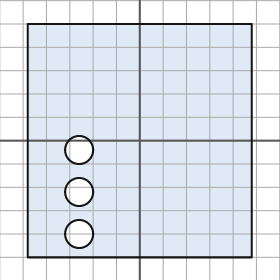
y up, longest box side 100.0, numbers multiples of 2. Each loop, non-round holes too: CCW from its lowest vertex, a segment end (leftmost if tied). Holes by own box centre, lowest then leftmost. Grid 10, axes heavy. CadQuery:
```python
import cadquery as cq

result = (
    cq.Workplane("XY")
    .moveTo(-48.0, -50.0)
    .lineTo(48.0, -50.0)
    .lineTo(48.0, 50.0)
    .lineTo(-48.0, 50.0)
    .close()
    .moveTo(-26.0, -40.0)
    .circle(6.0)
    .moveTo(-26.0, -22.0)
    .circle(6.0)
    .moveTo(-26.0, -4.0)
    .circle(6.0)
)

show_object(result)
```